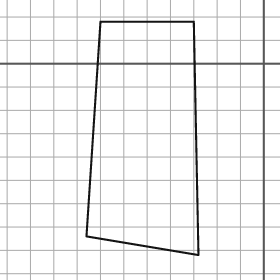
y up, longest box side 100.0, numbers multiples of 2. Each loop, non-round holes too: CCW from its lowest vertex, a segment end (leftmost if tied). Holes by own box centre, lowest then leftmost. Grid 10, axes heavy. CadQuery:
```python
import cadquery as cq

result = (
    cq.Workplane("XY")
    .moveTo(-28.0, -82.0)
    .lineTo(-30.0, 18.0)
    .lineTo(-70.0, 18.0)
    .lineTo(-76.0, -74.0)
    .close()
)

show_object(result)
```